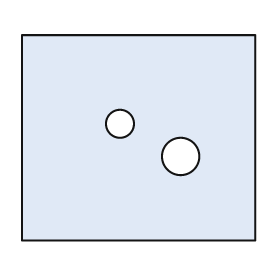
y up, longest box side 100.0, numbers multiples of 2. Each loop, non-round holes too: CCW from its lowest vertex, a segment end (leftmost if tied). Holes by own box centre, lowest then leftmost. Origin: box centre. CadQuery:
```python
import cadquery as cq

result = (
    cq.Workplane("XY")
    .moveTo(-50.0, -44.0)
    .lineTo(50.0, -44.0)
    .lineTo(50.0, 44.0)
    .lineTo(-50.0, 44.0)
    .close()
    .moveTo(18.0, -8.0)
    .circle(8.0)
    .moveTo(-8.0, 6.0)
    .circle(6.0)
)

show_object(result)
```